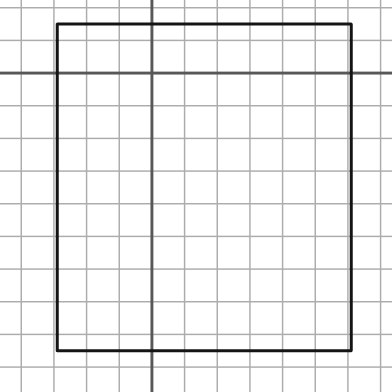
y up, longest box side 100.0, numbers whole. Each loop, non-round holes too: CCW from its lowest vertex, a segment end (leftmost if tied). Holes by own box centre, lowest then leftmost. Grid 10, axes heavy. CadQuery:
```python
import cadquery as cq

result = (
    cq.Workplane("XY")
    .moveTo(-29.0, -85.0)
    .lineTo(61.0, -85.0)
    .lineTo(61.0, 15.0)
    .lineTo(-29.0, 15.0)
    .close()
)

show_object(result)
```